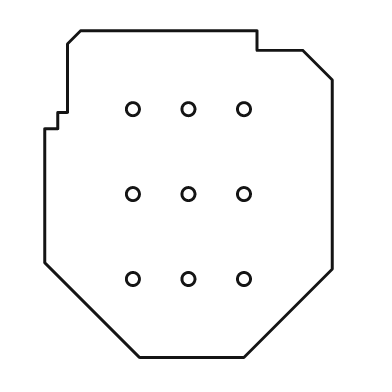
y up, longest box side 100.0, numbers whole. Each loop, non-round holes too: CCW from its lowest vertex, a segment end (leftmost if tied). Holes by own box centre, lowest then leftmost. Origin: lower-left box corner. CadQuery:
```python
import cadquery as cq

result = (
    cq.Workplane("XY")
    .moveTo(29.0, 0.0)
    .lineTo(61.0, 0.0)
    .lineTo(88.0, 27.0)
    .lineTo(88.0, 85.0)
    .lineTo(79.0, 94.0)
    .lineTo(65.0, 94.0)
    .lineTo(65.0, 100.0)
    .lineTo(11.0, 100.0)
    .lineTo(7.0, 96.0)
    .lineTo(7.0, 75.0)
    .lineTo(4.0, 75.0)
    .lineTo(4.0, 70.0)
    .lineTo(0.0, 70.0)
    .lineTo(0.0, 29.0)
    .close()
    .moveTo(27.0, 24.0)
    .circle(2.0)
    .moveTo(44.0, 24.0)
    .circle(2.0)
    .moveTo(61.0, 24.0)
    .circle(2.0)
    .moveTo(27.0, 50.0)
    .circle(2.0)
    .moveTo(44.0, 50.0)
    .circle(2.0)
    .moveTo(61.0, 50.0)
    .circle(2.0)
    .moveTo(27.0, 76.0)
    .circle(2.0)
    .moveTo(44.0, 76.0)
    .circle(2.0)
    .moveTo(61.0, 76.0)
    .circle(2.0)
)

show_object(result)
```